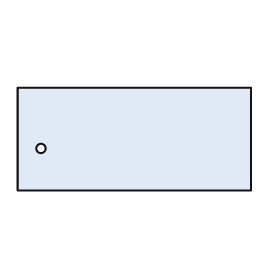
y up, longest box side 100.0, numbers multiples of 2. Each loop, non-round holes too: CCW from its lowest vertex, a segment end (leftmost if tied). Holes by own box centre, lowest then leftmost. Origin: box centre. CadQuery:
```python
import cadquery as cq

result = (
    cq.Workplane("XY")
    .moveTo(-50.0, -22.0)
    .lineTo(50.0, -22.0)
    .lineTo(50.0, 22.0)
    .lineTo(-50.0, 22.0)
    .close()
    .moveTo(-40.0, -4.0)
    .circle(2.0)
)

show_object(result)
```